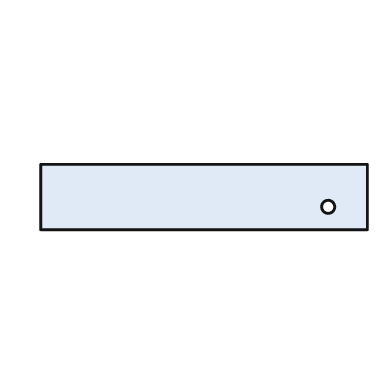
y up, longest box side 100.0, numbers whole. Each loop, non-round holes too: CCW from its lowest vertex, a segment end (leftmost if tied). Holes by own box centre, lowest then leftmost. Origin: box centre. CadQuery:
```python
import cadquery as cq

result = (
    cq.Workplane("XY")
    .moveTo(-50.0, -10.0)
    .lineTo(50.0, -10.0)
    .lineTo(50.0, 10.0)
    .lineTo(-50.0, 10.0)
    .close()
    .moveTo(38.0, -3.0)
    .circle(2.0)
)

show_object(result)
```